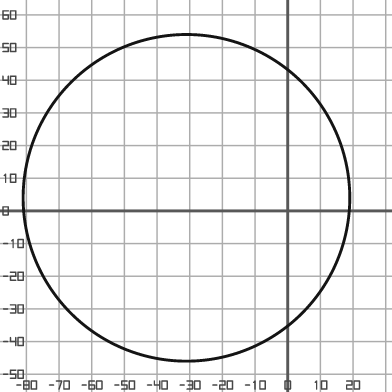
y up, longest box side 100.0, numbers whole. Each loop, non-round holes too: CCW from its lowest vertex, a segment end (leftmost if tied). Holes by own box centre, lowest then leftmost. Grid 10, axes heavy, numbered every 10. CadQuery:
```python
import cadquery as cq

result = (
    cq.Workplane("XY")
    .moveTo(-31.0, 4.0)
    .circle(50.0)
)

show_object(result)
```